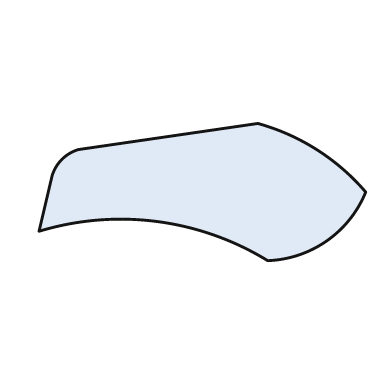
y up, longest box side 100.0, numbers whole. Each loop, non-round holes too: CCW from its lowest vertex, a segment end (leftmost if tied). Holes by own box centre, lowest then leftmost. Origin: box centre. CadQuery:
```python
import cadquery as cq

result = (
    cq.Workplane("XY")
    .moveTo(20.0, -21.0)
    .threePointArc((38.0, -15.0), (50.0, 0.0))
    .threePointArc((35.0, 13.0), (17.0, 21.0))
    .lineTo(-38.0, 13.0)
    .threePointArc((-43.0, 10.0), (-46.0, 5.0))
    .lineTo(-50.0, -12.0)
    .threePointArc((-14.0, -9.0), (20.0, -21.0))
    .close()
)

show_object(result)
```